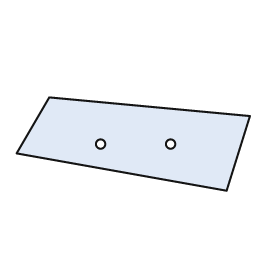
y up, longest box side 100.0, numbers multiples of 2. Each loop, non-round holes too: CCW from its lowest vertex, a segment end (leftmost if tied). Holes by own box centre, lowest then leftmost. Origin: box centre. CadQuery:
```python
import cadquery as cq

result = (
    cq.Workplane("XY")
    .moveTo(40.0, -20.0)
    .lineTo(50.0, 12.0)
    .lineTo(-36.0, 20.0)
    .lineTo(-50.0, -4.0)
    .close()
    .moveTo(-14.0, 0.0)
    .circle(2.0)
    .moveTo(16.0, 0.0)
    .circle(2.0)
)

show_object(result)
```